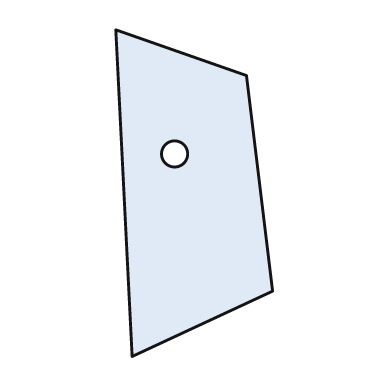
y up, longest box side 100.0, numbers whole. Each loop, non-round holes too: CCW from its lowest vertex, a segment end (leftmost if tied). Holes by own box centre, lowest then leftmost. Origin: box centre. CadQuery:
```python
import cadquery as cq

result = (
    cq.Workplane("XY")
    .moveTo(-19.0, -50.0)
    .lineTo(24.0, -30.0)
    .lineTo(16.0, 36.0)
    .lineTo(-24.0, 50.0)
    .close()
    .moveTo(-6.0, 12.0)
    .circle(4.0)
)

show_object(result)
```